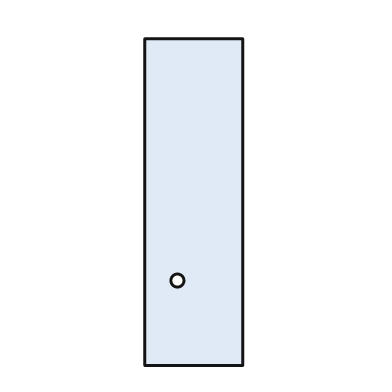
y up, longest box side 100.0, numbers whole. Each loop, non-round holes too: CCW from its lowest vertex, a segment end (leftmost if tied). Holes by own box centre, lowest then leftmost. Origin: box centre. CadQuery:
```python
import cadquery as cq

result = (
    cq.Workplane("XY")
    .moveTo(-15.0, -50.0)
    .lineTo(15.0, -50.0)
    .lineTo(15.0, 50.0)
    .lineTo(-15.0, 50.0)
    .close()
    .moveTo(-5.0, -24.0)
    .circle(2.0)
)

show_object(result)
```